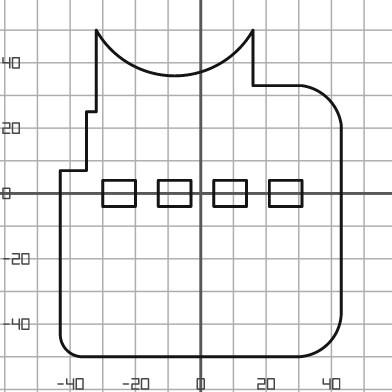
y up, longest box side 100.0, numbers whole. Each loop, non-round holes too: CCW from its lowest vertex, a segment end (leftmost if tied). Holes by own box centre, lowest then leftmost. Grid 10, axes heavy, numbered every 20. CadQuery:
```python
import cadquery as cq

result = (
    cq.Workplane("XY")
    .moveTo(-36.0, -50.0)
    .lineTo(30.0, -50.0)
    .threePointArc((39.0, -46.0), (43.0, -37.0))
    .lineTo(43.0, 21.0)
    .threePointArc((39.0, 29.0), (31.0, 33.0))
    .lineTo(16.0, 33.0)
    .lineTo(16.0, 50.0)
    .threePointArc((-8.0, 36.0), (-32.0, 50.0))
    .lineTo(-32.0, 25.0)
    .lineTo(-35.0, 25.0)
    .lineTo(-35.0, 7.0)
    .lineTo(-43.0, 7.0)
    .lineTo(-43.0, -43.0)
    .threePointArc((-41.0, -48.0), (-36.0, -50.0))
    .close()
    .moveTo(-30.0, -4.0)
    .lineTo(-20.0, -4.0)
    .lineTo(-20.0, 4.0)
    .lineTo(-30.0, 4.0)
    .close()
    .moveTo(-13.0, -4.0)
    .lineTo(-3.0, -4.0)
    .lineTo(-3.0, 4.0)
    .lineTo(-13.0, 4.0)
    .close()
    .moveTo(4.0, -4.0)
    .lineTo(14.0, -4.0)
    .lineTo(14.0, 4.0)
    .lineTo(4.0, 4.0)
    .close()
    .moveTo(21.0, -4.0)
    .lineTo(31.0, -4.0)
    .lineTo(31.0, 4.0)
    .lineTo(21.0, 4.0)
    .close()
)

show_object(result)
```